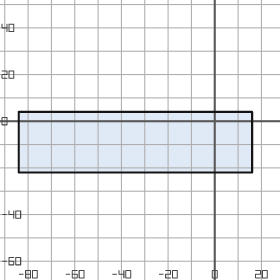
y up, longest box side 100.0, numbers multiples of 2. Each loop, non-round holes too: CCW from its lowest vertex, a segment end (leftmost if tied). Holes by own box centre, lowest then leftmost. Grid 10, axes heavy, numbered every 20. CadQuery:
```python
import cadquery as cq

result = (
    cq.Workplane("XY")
    .moveTo(-84.0, -22.0)
    .lineTo(16.0, -22.0)
    .lineTo(16.0, 4.0)
    .lineTo(-84.0, 4.0)
    .close()
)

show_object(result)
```